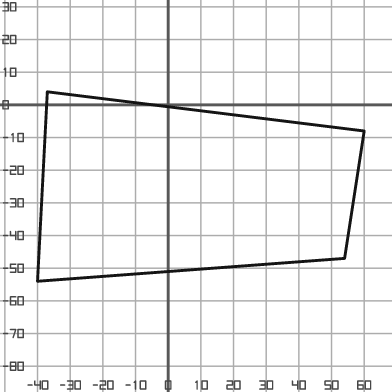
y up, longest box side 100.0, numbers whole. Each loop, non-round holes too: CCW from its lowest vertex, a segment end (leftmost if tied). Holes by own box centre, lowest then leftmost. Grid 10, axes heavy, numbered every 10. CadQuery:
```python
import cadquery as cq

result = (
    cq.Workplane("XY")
    .moveTo(-40.0, -54.0)
    .lineTo(54.0, -47.0)
    .lineTo(60.0, -8.0)
    .lineTo(-37.0, 4.0)
    .close()
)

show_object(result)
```